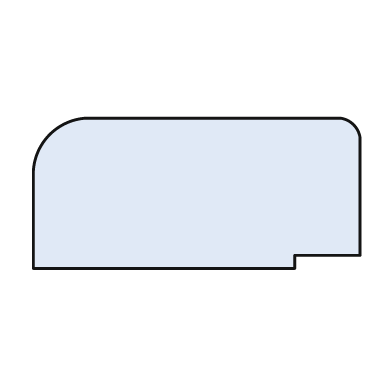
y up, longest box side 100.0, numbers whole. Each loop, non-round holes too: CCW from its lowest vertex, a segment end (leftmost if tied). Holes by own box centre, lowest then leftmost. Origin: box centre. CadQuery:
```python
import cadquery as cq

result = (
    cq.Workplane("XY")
    .moveTo(-50.0, -23.0)
    .lineTo(30.0, -23.0)
    .lineTo(30.0, -19.0)
    .lineTo(50.0, -19.0)
    .lineTo(50.0, 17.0)
    .threePointArc((48.0, 21.0), (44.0, 23.0))
    .lineTo(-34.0, 23.0)
    .threePointArc((-45.0, 18.0), (-50.0, 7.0))
    .close()
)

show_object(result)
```